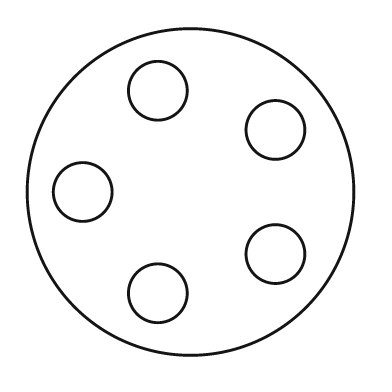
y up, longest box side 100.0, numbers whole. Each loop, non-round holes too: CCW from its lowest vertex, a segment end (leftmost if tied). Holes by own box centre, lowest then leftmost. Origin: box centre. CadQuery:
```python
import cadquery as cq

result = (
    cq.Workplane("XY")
    .moveTo(0.0, 0.0)
    .circle(50.0)
    .moveTo(-10.0, -31.0)
    .circle(9.0)
    .moveTo(26.0, -19.0)
    .circle(9.0)
    .moveTo(-33.0, 0.0)
    .circle(9.0)
    .moveTo(26.0, 19.0)
    .circle(9.0)
    .moveTo(-10.0, 31.0)
    .circle(9.0)
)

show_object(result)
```